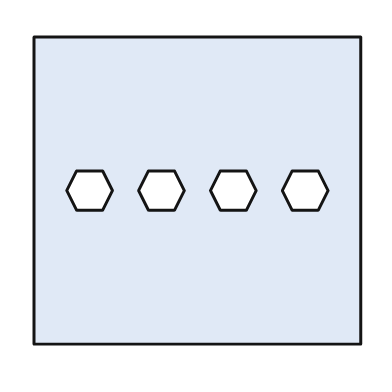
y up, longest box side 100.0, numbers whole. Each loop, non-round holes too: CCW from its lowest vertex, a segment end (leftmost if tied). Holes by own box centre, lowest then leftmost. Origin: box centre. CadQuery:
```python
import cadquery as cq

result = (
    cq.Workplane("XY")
    .moveTo(-50.0, -47.0)
    .lineTo(50.0, -47.0)
    .lineTo(50.0, 47.0)
    .lineTo(-50.0, 47.0)
    .close()
    .moveTo(-37.0, -6.0)
    .lineTo(-29.0, -6.0)
    .lineTo(-26.0, 0.0)
    .lineTo(-29.0, 6.0)
    .lineTo(-37.0, 6.0)
    .lineTo(-40.0, 0.0)
    .close()
    .moveTo(-15.0, -6.0)
    .lineTo(-7.0, -6.0)
    .lineTo(-4.0, 0.0)
    .lineTo(-7.0, 6.0)
    .lineTo(-15.0, 6.0)
    .lineTo(-18.0, 0.0)
    .close()
    .moveTo(7.0, -6.0)
    .lineTo(15.0, -6.0)
    .lineTo(18.0, 0.0)
    .lineTo(15.0, 6.0)
    .lineTo(7.0, 6.0)
    .lineTo(4.0, 0.0)
    .close()
    .moveTo(29.0, -6.0)
    .lineTo(37.0, -6.0)
    .lineTo(40.0, 0.0)
    .lineTo(37.0, 6.0)
    .lineTo(29.0, 6.0)
    .lineTo(26.0, 0.0)
    .close()
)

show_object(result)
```